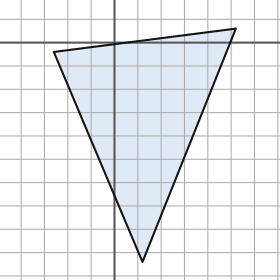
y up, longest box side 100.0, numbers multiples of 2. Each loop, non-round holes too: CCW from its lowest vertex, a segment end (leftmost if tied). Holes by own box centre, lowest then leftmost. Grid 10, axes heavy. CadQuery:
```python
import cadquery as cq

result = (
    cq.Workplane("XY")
    .moveTo(12.0, -94.0)
    .lineTo(52.0, 6.0)
    .lineTo(-26.0, -4.0)
    .close()
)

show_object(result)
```